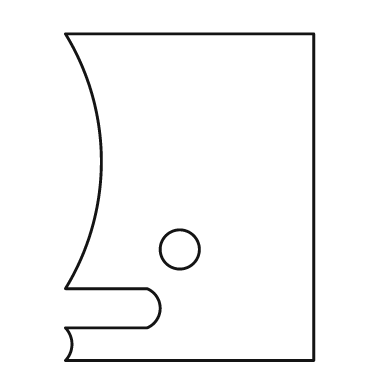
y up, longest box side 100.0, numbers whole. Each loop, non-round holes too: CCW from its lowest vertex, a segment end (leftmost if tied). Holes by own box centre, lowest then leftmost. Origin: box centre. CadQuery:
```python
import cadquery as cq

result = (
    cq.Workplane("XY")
    .moveTo(-38.0, -50.0)
    .lineTo(38.0, -50.0)
    .lineTo(38.0, 50.0)
    .lineTo(-38.0, 50.0)
    .threePointArc((-27.0, 11.0), (-38.0, -28.0))
    .lineTo(-13.0, -28.0)
    .threePointArc((-9.0, -34.0), (-13.0, -40.0))
    .lineTo(-38.0, -40.0)
    .threePointArc((-36.0, -45.0), (-38.0, -50.0))
    .close()
    .moveTo(-3.0, -16.0)
    .circle(6.0)
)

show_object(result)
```